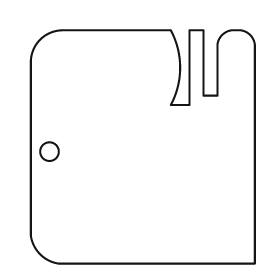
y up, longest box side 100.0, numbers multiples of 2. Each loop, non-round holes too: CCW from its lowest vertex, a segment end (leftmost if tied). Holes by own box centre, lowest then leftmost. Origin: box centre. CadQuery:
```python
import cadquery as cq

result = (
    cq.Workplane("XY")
    .moveTo(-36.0, -50.0)
    .lineTo(48.0, -50.0)
    .lineTo(48.0, 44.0)
    .threePointArc((46.0, 48.0), (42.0, 50.0))
    .lineTo(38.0, 50.0)
    .threePointArc((34.0, 48.0), (32.0, 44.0))
    .lineTo(32.0, 22.0)
    .lineTo(26.0, 22.0)
    .lineTo(26.0, 50.0)
    .lineTo(20.0, 50.0)
    .lineTo(20.0, 18.0)
    .lineTo(12.0, 18.0)
    .threePointArc((16.0, 34.0), (12.0, 50.0))
    .lineTo(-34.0, 50.0)
    .threePointArc((-44.0, 46.0), (-48.0, 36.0))
    .lineTo(-48.0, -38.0)
    .threePointArc((-44.0, -46.0), (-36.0, -50.0))
    .close()
    .moveTo(-40.0, -2.0)
    .circle(4.0)
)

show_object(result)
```